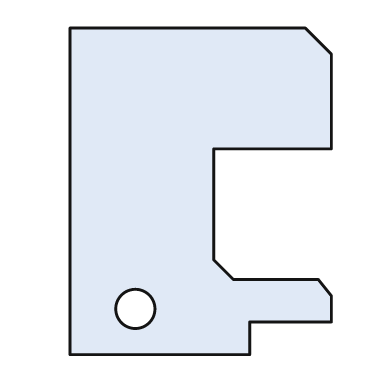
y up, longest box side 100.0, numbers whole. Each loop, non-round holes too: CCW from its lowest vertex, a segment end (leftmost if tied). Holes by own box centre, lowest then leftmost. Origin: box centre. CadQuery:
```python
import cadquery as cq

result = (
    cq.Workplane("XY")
    .moveTo(-40.0, -50.0)
    .lineTo(15.0, -50.0)
    .lineTo(15.0, -40.0)
    .lineTo(40.0, -40.0)
    .lineTo(40.0, -32.0)
    .lineTo(36.0, -27.0)
    .lineTo(10.0, -27.0)
    .lineTo(4.0, -21.0)
    .lineTo(4.0, 13.0)
    .lineTo(40.0, 13.0)
    .lineTo(40.0, 42.0)
    .lineTo(32.0, 50.0)
    .lineTo(-40.0, 50.0)
    .close()
    .moveTo(-20.0, -36.0)
    .circle(6.0)
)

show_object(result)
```